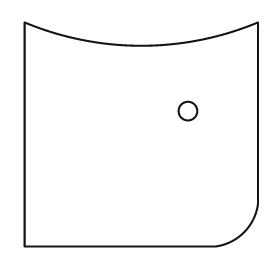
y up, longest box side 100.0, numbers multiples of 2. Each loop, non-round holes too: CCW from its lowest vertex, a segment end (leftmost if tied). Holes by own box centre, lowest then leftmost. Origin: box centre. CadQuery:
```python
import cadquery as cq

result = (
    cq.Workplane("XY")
    .moveTo(-50.0, -48.0)
    .lineTo(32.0, -48.0)
    .threePointArc((44.0, -42.0), (50.0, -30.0))
    .lineTo(50.0, 48.0)
    .threePointArc((0.0, 38.0), (-50.0, 48.0))
    .close()
    .moveTo(20.0, 10.0)
    .circle(4.0)
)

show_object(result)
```